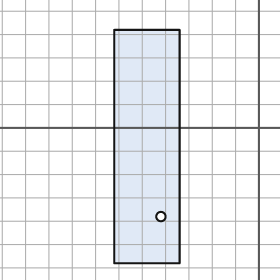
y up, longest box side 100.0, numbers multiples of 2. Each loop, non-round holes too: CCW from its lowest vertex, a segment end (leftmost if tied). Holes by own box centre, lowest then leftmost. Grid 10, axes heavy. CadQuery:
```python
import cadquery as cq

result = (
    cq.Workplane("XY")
    .moveTo(-62.0, -58.0)
    .lineTo(-34.0, -58.0)
    .lineTo(-34.0, 42.0)
    .lineTo(-62.0, 42.0)
    .close()
    .moveTo(-42.0, -38.0)
    .circle(2.0)
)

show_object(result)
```